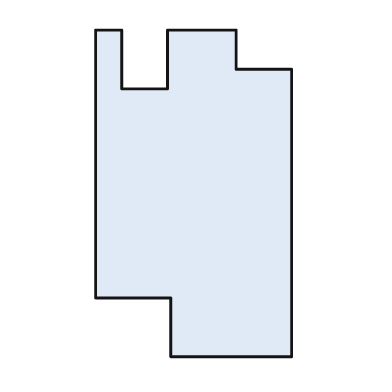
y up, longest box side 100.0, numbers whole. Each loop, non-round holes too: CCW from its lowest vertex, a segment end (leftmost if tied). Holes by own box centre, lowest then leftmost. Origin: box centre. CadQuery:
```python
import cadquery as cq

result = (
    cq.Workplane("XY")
    .moveTo(-7.0, -50.0)
    .lineTo(30.0, -50.0)
    .lineTo(30.0, 38.0)
    .lineTo(13.0, 38.0)
    .lineTo(13.0, 50.0)
    .lineTo(-8.0, 50.0)
    .lineTo(-8.0, 32.0)
    .lineTo(-22.0, 32.0)
    .lineTo(-22.0, 50.0)
    .lineTo(-30.0, 50.0)
    .lineTo(-30.0, -32.0)
    .lineTo(-7.0, -32.0)
    .close()
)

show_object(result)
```